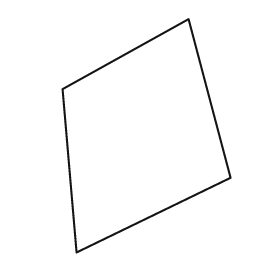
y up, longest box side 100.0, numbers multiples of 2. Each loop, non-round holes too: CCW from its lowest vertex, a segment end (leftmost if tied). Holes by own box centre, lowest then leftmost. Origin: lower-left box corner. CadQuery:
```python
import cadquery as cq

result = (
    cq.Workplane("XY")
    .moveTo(6.0, 0.0)
    .lineTo(72.0, 32.0)
    .lineTo(54.0, 100.0)
    .lineTo(0.0, 70.0)
    .close()
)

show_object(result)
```